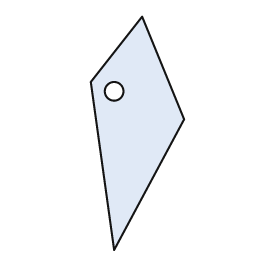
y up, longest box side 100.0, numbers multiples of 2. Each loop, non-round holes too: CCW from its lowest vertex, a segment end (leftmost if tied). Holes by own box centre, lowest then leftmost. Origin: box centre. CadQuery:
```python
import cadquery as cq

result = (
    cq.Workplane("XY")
    .moveTo(-10.0, -50.0)
    .lineTo(20.0, 6.0)
    .lineTo(2.0, 50.0)
    .lineTo(-20.0, 22.0)
    .close()
    .moveTo(-10.0, 18.0)
    .circle(4.0)
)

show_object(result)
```